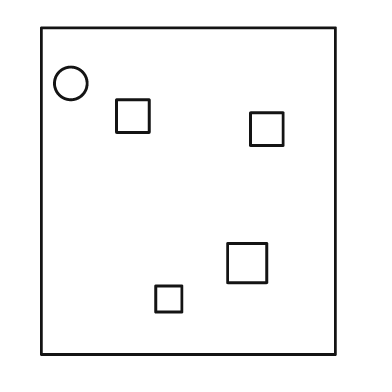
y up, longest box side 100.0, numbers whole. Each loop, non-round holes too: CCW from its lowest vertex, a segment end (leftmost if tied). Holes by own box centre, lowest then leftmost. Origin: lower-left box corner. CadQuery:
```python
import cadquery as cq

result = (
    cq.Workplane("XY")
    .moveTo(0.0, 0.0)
    .lineTo(90.0, 0.0)
    .lineTo(90.0, 100.0)
    .lineTo(0.0, 100.0)
    .close()
    .moveTo(35.0, 13.0)
    .lineTo(43.0, 13.0)
    .lineTo(43.0, 21.0)
    .lineTo(35.0, 21.0)
    .close()
    .moveTo(57.0, 22.0)
    .lineTo(69.0, 22.0)
    .lineTo(69.0, 34.0)
    .lineTo(57.0, 34.0)
    .close()
    .moveTo(64.0, 64.0)
    .lineTo(74.0, 64.0)
    .lineTo(74.0, 74.0)
    .lineTo(64.0, 74.0)
    .close()
    .moveTo(23.0, 68.0)
    .lineTo(33.0, 68.0)
    .lineTo(33.0, 78.0)
    .lineTo(23.0, 78.0)
    .close()
    .moveTo(9.0, 83.0)
    .circle(5.0)
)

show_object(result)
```